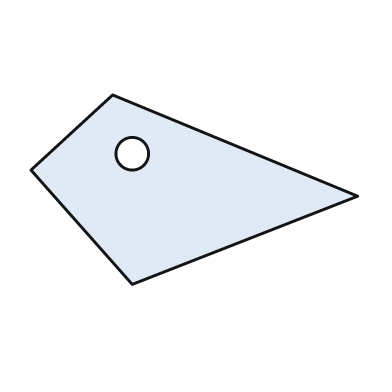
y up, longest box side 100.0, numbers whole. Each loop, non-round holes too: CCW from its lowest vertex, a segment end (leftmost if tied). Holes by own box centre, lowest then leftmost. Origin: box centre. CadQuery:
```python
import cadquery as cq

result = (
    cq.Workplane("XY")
    .moveTo(-19.0, -29.0)
    .lineTo(50.0, -2.0)
    .lineTo(-25.0, 29.0)
    .lineTo(-50.0, 6.0)
    .close()
    .moveTo(-19.0, 11.0)
    .circle(5.0)
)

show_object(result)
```